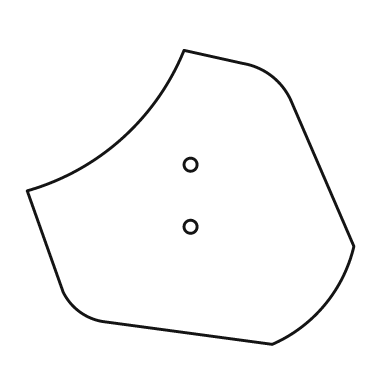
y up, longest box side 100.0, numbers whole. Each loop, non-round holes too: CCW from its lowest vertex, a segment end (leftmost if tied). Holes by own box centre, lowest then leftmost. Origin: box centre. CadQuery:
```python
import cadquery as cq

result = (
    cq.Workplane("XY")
    .moveTo(25.0, -45.0)
    .threePointArc((41.0, -33.0), (50.0, -15.0))
    .lineTo(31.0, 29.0)
    .threePointArc((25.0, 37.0), (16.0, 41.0))
    .lineTo(-2.0, 45.0)
    .threePointArc((-21.0, 18.0), (-50.0, 2.0))
    .lineTo(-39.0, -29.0)
    .threePointArc((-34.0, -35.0), (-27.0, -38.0))
    .close()
    .moveTo(0.0, -9.0)
    .circle(2.0)
    .moveTo(0.0, 10.0)
    .circle(2.0)
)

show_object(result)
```